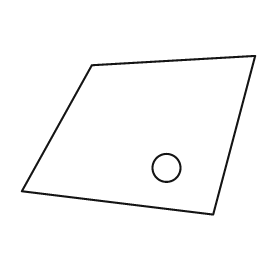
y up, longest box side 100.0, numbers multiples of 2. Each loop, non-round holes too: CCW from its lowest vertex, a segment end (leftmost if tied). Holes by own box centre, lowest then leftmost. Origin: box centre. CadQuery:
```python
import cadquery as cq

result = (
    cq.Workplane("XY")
    .moveTo(32.0, -34.0)
    .lineTo(50.0, 34.0)
    .lineTo(-20.0, 30.0)
    .lineTo(-50.0, -24.0)
    .close()
    .moveTo(12.0, -14.0)
    .circle(6.0)
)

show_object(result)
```